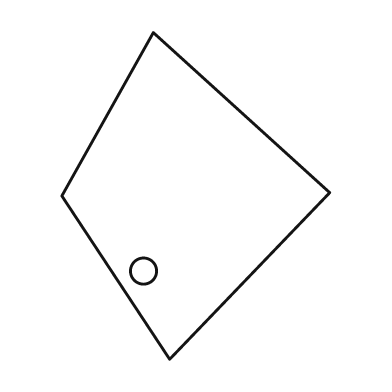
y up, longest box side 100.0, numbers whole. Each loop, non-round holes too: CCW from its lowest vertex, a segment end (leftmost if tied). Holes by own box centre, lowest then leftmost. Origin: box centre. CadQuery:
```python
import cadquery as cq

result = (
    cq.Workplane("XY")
    .moveTo(-8.0, -50.0)
    .lineTo(41.0, 1.0)
    .lineTo(-13.0, 50.0)
    .lineTo(-41.0, 0.0)
    .close()
    .moveTo(-16.0, -23.0)
    .circle(4.0)
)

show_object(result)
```